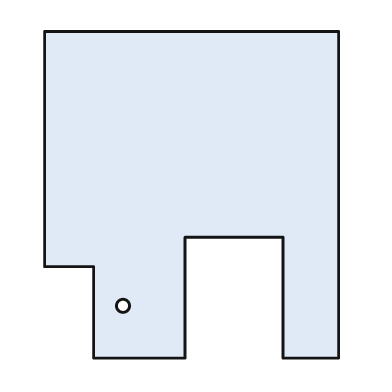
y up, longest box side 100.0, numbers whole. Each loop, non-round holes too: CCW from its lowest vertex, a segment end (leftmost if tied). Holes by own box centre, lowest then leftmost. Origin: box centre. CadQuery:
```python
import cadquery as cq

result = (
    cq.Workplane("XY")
    .moveTo(-30.0, -50.0)
    .lineTo(-2.0, -50.0)
    .lineTo(-2.0, -13.0)
    .lineTo(28.0, -13.0)
    .lineTo(28.0, -50.0)
    .lineTo(45.0, -50.0)
    .lineTo(45.0, 50.0)
    .lineTo(-45.0, 50.0)
    .lineTo(-45.0, -22.0)
    .lineTo(-30.0, -22.0)
    .close()
    .moveTo(-21.0, -34.0)
    .circle(2.0)
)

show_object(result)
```